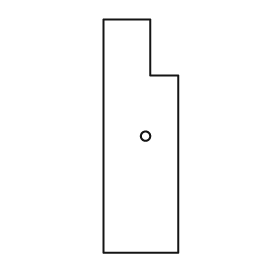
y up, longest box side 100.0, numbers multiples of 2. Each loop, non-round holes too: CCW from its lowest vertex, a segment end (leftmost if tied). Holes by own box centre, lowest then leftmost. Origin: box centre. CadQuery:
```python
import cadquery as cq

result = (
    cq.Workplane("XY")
    .moveTo(-16.0, -50.0)
    .lineTo(16.0, -50.0)
    .lineTo(16.0, 26.0)
    .lineTo(4.0, 26.0)
    .lineTo(4.0, 50.0)
    .lineTo(-16.0, 50.0)
    .close()
    .moveTo(2.0, 0.0)
    .circle(2.0)
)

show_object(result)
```